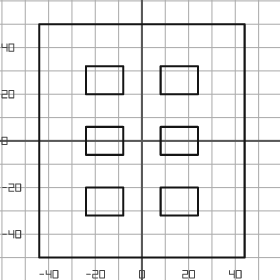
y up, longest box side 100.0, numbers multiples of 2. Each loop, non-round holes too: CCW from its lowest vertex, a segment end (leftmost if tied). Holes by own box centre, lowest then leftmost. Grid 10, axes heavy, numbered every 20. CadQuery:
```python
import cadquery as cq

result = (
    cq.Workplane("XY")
    .moveTo(-44.0, -50.0)
    .lineTo(44.0, -50.0)
    .lineTo(44.0, 50.0)
    .lineTo(-44.0, 50.0)
    .close()
    .moveTo(-24.0, -32.0)
    .lineTo(-8.0, -32.0)
    .lineTo(-8.0, -20.0)
    .lineTo(-24.0, -20.0)
    .close()
    .moveTo(8.0, -32.0)
    .lineTo(24.0, -32.0)
    .lineTo(24.0, -20.0)
    .lineTo(8.0, -20.0)
    .close()
    .moveTo(-24.0, -6.0)
    .lineTo(-8.0, -6.0)
    .lineTo(-8.0, 6.0)
    .lineTo(-24.0, 6.0)
    .close()
    .moveTo(8.0, -6.0)
    .lineTo(24.0, -6.0)
    .lineTo(24.0, 6.0)
    .lineTo(8.0, 6.0)
    .close()
    .moveTo(-24.0, 20.0)
    .lineTo(-8.0, 20.0)
    .lineTo(-8.0, 32.0)
    .lineTo(-24.0, 32.0)
    .close()
    .moveTo(8.0, 20.0)
    .lineTo(24.0, 20.0)
    .lineTo(24.0, 32.0)
    .lineTo(8.0, 32.0)
    .close()
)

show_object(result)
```